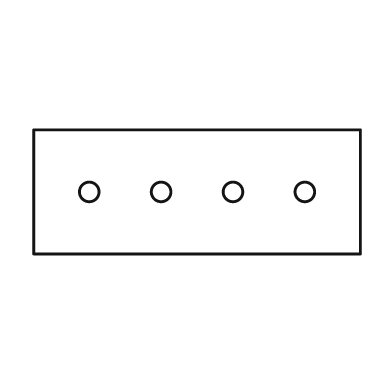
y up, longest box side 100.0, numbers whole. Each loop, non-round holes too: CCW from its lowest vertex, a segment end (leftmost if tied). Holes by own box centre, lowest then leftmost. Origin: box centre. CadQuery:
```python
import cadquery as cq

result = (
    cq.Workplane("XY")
    .moveTo(-50.0, -19.0)
    .lineTo(50.0, -19.0)
    .lineTo(50.0, 19.0)
    .lineTo(-50.0, 19.0)
    .close()
    .moveTo(-33.0, 0.0)
    .circle(3.0)
    .moveTo(-11.0, 0.0)
    .circle(3.0)
    .moveTo(11.0, 0.0)
    .circle(3.0)
    .moveTo(33.0, 0.0)
    .circle(3.0)
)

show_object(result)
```